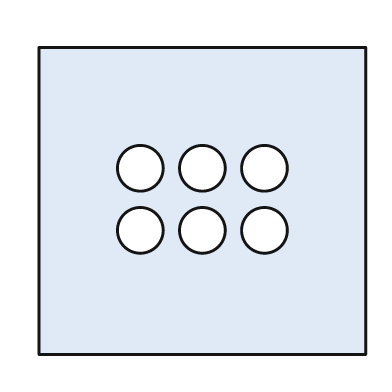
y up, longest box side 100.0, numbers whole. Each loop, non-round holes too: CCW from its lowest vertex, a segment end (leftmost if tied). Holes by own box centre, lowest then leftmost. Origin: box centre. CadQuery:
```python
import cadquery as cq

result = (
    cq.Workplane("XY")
    .moveTo(-50.0, -47.0)
    .lineTo(50.0, -47.0)
    .lineTo(50.0, 47.0)
    .lineTo(-50.0, 47.0)
    .close()
    .moveTo(-19.0, -9.0)
    .circle(7.0)
    .moveTo(0.0, -9.0)
    .circle(7.0)
    .moveTo(19.0, -9.0)
    .circle(7.0)
    .moveTo(-19.0, 10.0)
    .circle(7.0)
    .moveTo(0.0, 10.0)
    .circle(7.0)
    .moveTo(19.0, 10.0)
    .circle(7.0)
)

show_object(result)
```